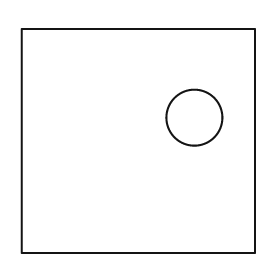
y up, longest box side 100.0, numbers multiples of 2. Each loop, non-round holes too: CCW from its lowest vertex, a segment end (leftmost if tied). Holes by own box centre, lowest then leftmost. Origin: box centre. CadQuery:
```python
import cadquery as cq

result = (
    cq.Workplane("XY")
    .moveTo(-50.0, -48.0)
    .lineTo(50.0, -48.0)
    .lineTo(50.0, 48.0)
    .lineTo(-50.0, 48.0)
    .close()
    .moveTo(24.0, 10.0)
    .circle(12.0)
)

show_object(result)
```